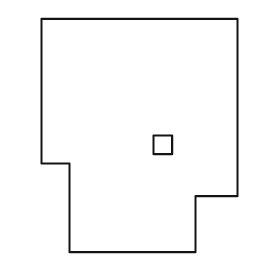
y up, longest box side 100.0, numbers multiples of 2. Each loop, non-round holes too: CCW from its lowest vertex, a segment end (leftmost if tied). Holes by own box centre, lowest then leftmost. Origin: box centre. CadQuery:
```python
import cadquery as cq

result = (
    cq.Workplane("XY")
    .moveTo(-30.0, -50.0)
    .lineTo(24.0, -50.0)
    .lineTo(24.0, -26.0)
    .lineTo(42.0, -26.0)
    .lineTo(42.0, 50.0)
    .lineTo(-42.0, 50.0)
    .lineTo(-42.0, -12.0)
    .lineTo(-30.0, -12.0)
    .close()
    .moveTo(6.0, -8.0)
    .lineTo(14.0, -8.0)
    .lineTo(14.0, 0.0)
    .lineTo(6.0, 0.0)
    .close()
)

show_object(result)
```